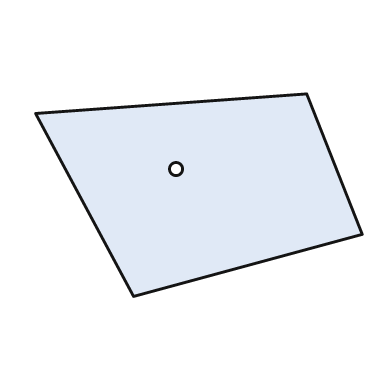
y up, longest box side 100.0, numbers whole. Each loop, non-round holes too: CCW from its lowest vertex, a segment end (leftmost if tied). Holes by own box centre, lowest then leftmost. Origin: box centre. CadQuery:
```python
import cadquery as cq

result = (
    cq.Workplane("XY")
    .moveTo(-20.0, -31.0)
    .lineTo(50.0, -12.0)
    .lineTo(33.0, 31.0)
    .lineTo(-50.0, 25.0)
    .close()
    .moveTo(-7.0, 8.0)
    .circle(2.0)
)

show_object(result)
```